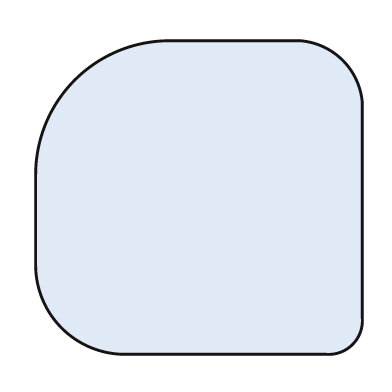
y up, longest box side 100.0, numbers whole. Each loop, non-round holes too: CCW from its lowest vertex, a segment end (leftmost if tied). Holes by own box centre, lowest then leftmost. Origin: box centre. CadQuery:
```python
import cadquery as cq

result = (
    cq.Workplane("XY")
    .moveTo(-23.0, -48.0)
    .lineTo(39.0, -48.0)
    .threePointArc((47.0, -45.0), (50.0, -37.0))
    .lineTo(50.0, 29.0)
    .threePointArc((44.0, 42.0), (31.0, 48.0))
    .lineTo(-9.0, 48.0)
    .threePointArc((-38.0, 36.0), (-50.0, 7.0))
    .lineTo(-50.0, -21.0)
    .threePointArc((-42.0, -40.0), (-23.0, -48.0))
    .close()
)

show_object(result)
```